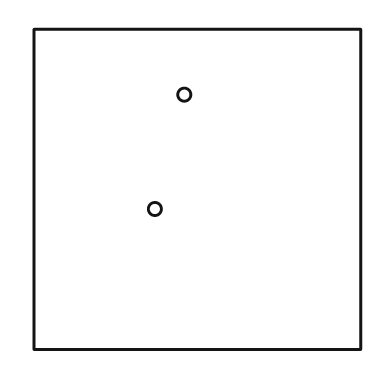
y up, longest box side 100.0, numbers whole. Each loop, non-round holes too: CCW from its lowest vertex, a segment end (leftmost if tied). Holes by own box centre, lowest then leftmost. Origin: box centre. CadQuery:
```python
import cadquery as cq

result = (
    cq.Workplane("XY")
    .moveTo(-50.0, -49.0)
    .lineTo(50.0, -49.0)
    .lineTo(50.0, 49.0)
    .lineTo(-50.0, 49.0)
    .close()
    .moveTo(-13.0, -6.0)
    .circle(2.0)
    .moveTo(-4.0, 29.0)
    .circle(2.0)
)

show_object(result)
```